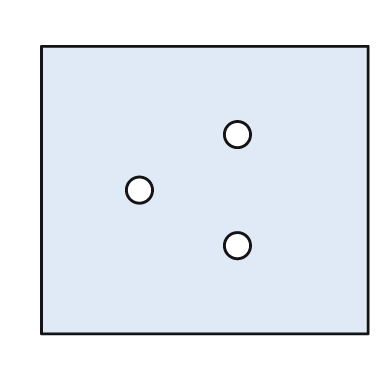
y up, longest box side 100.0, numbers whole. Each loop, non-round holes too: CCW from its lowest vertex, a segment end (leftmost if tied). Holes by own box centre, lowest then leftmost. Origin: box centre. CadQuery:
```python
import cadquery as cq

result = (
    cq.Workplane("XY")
    .moveTo(-50.0, -44.0)
    .lineTo(50.0, -44.0)
    .lineTo(50.0, 44.0)
    .lineTo(-50.0, 44.0)
    .close()
    .moveTo(10.0, -17.0)
    .circle(4.0)
    .moveTo(-20.0, 0.0)
    .circle(4.0)
    .moveTo(10.0, 17.0)
    .circle(4.0)
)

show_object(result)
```